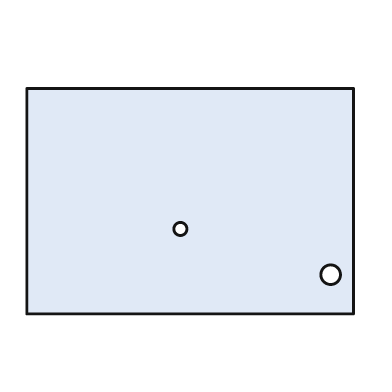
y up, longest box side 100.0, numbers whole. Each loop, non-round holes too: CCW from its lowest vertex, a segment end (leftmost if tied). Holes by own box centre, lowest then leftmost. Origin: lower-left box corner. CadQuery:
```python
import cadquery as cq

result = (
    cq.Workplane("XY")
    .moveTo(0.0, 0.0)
    .lineTo(100.0, 0.0)
    .lineTo(100.0, 69.0)
    .lineTo(0.0, 69.0)
    .close()
    .moveTo(93.0, 12.0)
    .circle(3.0)
    .moveTo(47.0, 26.0)
    .circle(2.0)
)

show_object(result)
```